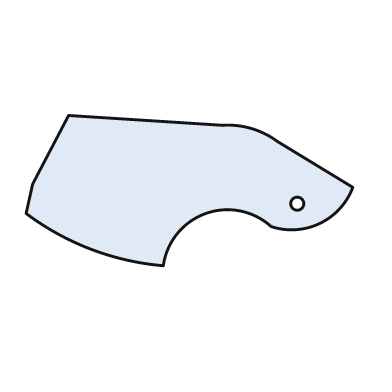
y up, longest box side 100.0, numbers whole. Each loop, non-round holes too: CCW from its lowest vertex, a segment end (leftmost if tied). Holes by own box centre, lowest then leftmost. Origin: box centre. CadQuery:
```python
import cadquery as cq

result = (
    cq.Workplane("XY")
    .moveTo(-8.0, -23.0)
    .threePointArc((5.0, -7.0), (25.0, -11.0))
    .threePointArc((40.0, -10.0), (50.0, 1.0))
    .lineTo(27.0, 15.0)
    .threePointArc((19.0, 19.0), (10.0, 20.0))
    .lineTo(-37.0, 23.0)
    .lineTo(-48.0, 2.0)
    .lineTo(-50.0, -7.0)
    .threePointArc((-30.0, -18.0), (-8.0, -23.0))
    .close()
    .moveTo(33.0, -4.0)
    .circle(2.0)
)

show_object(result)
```